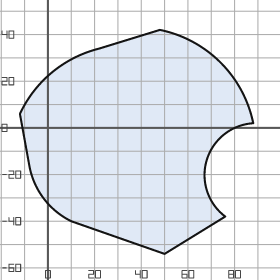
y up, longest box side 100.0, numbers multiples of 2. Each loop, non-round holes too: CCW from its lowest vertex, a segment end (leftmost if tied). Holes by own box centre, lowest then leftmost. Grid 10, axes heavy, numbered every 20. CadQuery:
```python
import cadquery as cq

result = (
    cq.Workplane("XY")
    .moveTo(50.0, -54.0)
    .lineTo(76.0, -38.0)
    .threePointArc((68.0, -14.0), (88.0, 2.0))
    .threePointArc((74.0, 28.0), (48.0, 42.0))
    .lineTo(22.0, 34.0)
    .threePointArc((2.0, 24.0), (-12.0, 6.0))
    .lineTo(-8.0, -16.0)
    .threePointArc((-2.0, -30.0), (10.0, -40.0))
    .close()
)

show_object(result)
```